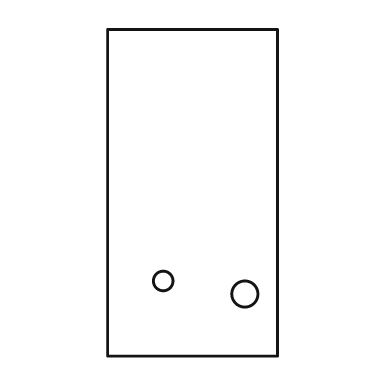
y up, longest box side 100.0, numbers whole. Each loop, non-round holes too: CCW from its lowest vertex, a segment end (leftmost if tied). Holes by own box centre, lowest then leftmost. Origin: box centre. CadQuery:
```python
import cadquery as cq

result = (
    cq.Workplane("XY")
    .moveTo(-26.0, -50.0)
    .lineTo(26.0, -50.0)
    .lineTo(26.0, 50.0)
    .lineTo(-26.0, 50.0)
    .close()
    .moveTo(16.0, -31.0)
    .circle(4.0)
    .moveTo(-9.0, -27.0)
    .circle(3.0)
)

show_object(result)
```